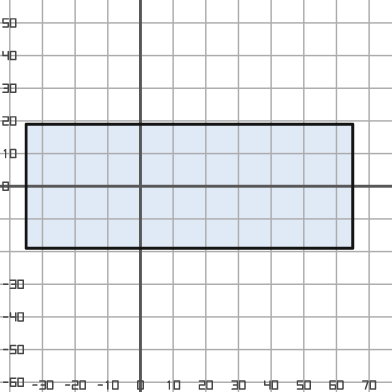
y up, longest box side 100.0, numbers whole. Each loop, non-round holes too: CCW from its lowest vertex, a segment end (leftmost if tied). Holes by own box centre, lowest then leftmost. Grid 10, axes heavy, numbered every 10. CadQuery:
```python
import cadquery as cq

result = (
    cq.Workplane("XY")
    .moveTo(-35.0, -19.0)
    .lineTo(65.0, -19.0)
    .lineTo(65.0, 19.0)
    .lineTo(-35.0, 19.0)
    .close()
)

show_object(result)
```